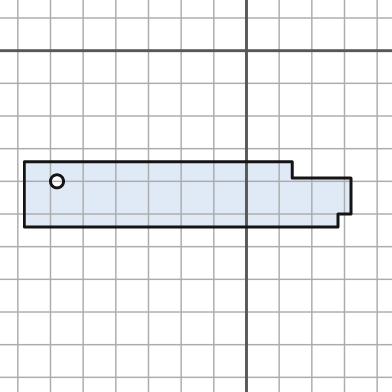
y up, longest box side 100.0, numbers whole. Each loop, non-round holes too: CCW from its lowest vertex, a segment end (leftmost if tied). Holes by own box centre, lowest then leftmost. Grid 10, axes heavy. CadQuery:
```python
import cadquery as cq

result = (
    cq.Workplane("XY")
    .moveTo(-68.0, -54.0)
    .lineTo(28.0, -54.0)
    .lineTo(28.0, -50.0)
    .lineTo(32.0, -50.0)
    .lineTo(32.0, -39.0)
    .lineTo(14.0, -39.0)
    .lineTo(14.0, -34.0)
    .lineTo(-68.0, -34.0)
    .close()
    .moveTo(-58.0, -40.0)
    .circle(2.0)
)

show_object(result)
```